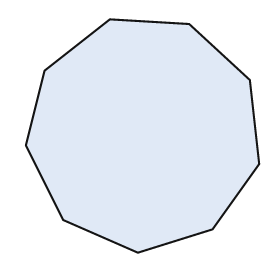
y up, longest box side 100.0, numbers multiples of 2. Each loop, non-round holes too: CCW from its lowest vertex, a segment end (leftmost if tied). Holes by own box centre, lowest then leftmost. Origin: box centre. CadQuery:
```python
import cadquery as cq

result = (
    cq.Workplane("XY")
    .moveTo(-2.0, -50.0)
    .lineTo(30.0, -40.0)
    .lineTo(50.0, -12.0)
    .lineTo(46.0, 24.0)
    .lineTo(20.0, 48.0)
    .lineTo(-14.0, 50.0)
    .lineTo(-42.0, 28.0)
    .lineTo(-50.0, -4.0)
    .lineTo(-34.0, -36.0)
    .close()
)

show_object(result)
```